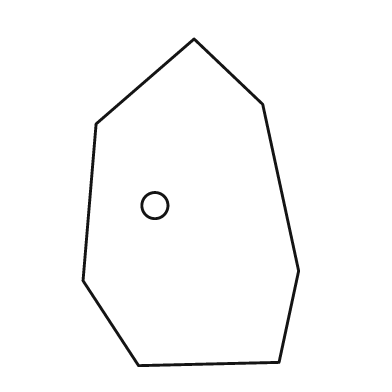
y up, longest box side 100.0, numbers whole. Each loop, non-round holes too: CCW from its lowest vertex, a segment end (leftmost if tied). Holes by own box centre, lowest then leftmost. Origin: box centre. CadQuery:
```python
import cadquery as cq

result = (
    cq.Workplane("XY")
    .moveTo(-16.0, -50.0)
    .lineTo(27.0, -49.0)
    .lineTo(33.0, -21.0)
    .lineTo(22.0, 30.0)
    .lineTo(1.0, 50.0)
    .lineTo(-29.0, 24.0)
    .lineTo(-33.0, -24.0)
    .close()
    .moveTo(-11.0, -1.0)
    .circle(4.0)
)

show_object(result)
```